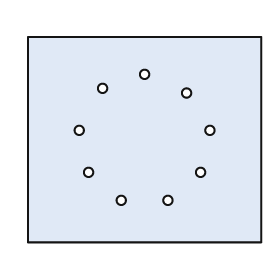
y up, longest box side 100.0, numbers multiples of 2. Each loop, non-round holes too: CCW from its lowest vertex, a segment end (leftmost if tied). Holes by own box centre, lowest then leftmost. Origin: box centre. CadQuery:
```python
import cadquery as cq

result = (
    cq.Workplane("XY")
    .moveTo(-50.0, -44.0)
    .lineTo(50.0, -44.0)
    .lineTo(50.0, 44.0)
    .lineTo(-50.0, 44.0)
    .close()
    .moveTo(-10.0, -26.0)
    .circle(2.0)
    .moveTo(10.0, -26.0)
    .circle(2.0)
    .moveTo(-24.0, -14.0)
    .circle(2.0)
    .moveTo(24.0, -14.0)
    .circle(2.0)
    .moveTo(-28.0, 4.0)
    .circle(2.0)
    .moveTo(28.0, 4.0)
    .circle(2.0)
    .moveTo(18.0, 20.0)
    .circle(2.0)
    .moveTo(-18.0, 22.0)
    .circle(2.0)
    .moveTo(0.0, 28.0)
    .circle(2.0)
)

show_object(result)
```